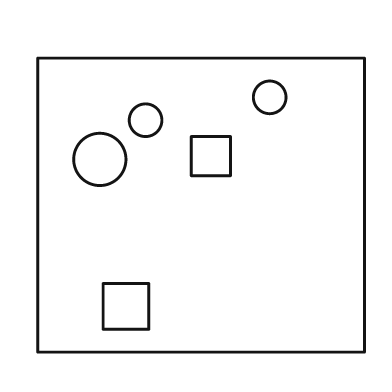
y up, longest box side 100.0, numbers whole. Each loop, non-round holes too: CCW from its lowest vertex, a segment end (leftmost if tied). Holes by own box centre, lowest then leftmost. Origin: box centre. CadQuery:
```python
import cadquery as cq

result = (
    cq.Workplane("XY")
    .moveTo(-50.0, -45.0)
    .lineTo(50.0, -45.0)
    .lineTo(50.0, 45.0)
    .lineTo(-50.0, 45.0)
    .close()
    .moveTo(-30.0, -38.0)
    .lineTo(-16.0, -38.0)
    .lineTo(-16.0, -24.0)
    .lineTo(-30.0, -24.0)
    .close()
    .moveTo(-31.0, 14.0)
    .circle(8.0)
    .moveTo(-3.0, 9.0)
    .lineTo(9.0, 9.0)
    .lineTo(9.0, 21.0)
    .lineTo(-3.0, 21.0)
    .close()
    .moveTo(-17.0, 26.0)
    .circle(5.0)
    .moveTo(21.0, 33.0)
    .circle(5.0)
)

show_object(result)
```